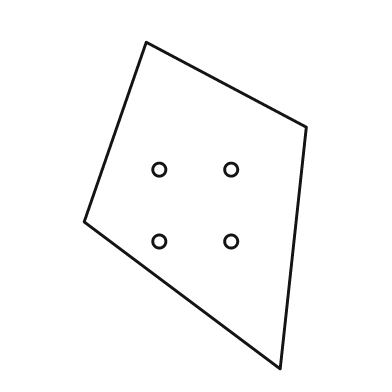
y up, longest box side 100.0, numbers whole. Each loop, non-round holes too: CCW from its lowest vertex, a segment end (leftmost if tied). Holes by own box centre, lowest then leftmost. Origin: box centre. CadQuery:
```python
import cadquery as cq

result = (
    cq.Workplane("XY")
    .moveTo(26.0, -50.0)
    .lineTo(34.0, 24.0)
    .lineTo(-15.0, 50.0)
    .lineTo(-34.0, -5.0)
    .close()
    .moveTo(-11.0, -11.0)
    .circle(2.0)
    .moveTo(11.0, -11.0)
    .circle(2.0)
    .moveTo(-11.0, 11.0)
    .circle(2.0)
    .moveTo(11.0, 11.0)
    .circle(2.0)
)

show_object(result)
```